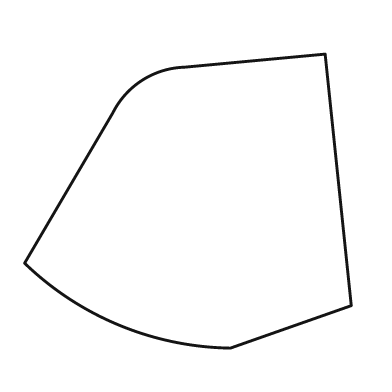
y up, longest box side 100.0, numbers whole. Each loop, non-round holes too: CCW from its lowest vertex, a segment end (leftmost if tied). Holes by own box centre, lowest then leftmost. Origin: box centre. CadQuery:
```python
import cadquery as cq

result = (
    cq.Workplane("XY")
    .moveTo(13.0, -45.0)
    .lineTo(50.0, -32.0)
    .lineTo(42.0, 45.0)
    .lineTo(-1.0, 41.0)
    .threePointArc((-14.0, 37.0), (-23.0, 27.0))
    .lineTo(-50.0, -19.0)
    .threePointArc((-21.0, -38.0), (13.0, -45.0))
    .close()
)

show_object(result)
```